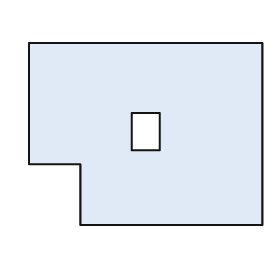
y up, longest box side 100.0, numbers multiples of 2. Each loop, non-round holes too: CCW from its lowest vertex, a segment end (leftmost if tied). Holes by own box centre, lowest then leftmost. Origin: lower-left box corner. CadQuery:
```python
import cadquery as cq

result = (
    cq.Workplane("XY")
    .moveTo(22.0, 0.0)
    .lineTo(100.0, 0.0)
    .lineTo(100.0, 78.0)
    .lineTo(0.0, 78.0)
    .lineTo(0.0, 26.0)
    .lineTo(22.0, 26.0)
    .close()
    .moveTo(44.0, 32.0)
    .lineTo(56.0, 32.0)
    .lineTo(56.0, 48.0)
    .lineTo(44.0, 48.0)
    .close()
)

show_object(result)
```